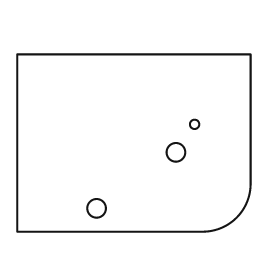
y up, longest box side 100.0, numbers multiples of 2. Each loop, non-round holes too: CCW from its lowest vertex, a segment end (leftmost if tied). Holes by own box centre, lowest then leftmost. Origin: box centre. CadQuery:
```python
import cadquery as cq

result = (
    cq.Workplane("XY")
    .moveTo(-50.0, -38.0)
    .lineTo(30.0, -38.0)
    .threePointArc((44.0, -32.0), (50.0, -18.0))
    .lineTo(50.0, 38.0)
    .lineTo(-50.0, 38.0)
    .close()
    .moveTo(-16.0, -28.0)
    .circle(4.0)
    .moveTo(18.0, -4.0)
    .circle(4.0)
    .moveTo(26.0, 8.0)
    .circle(2.0)
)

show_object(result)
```